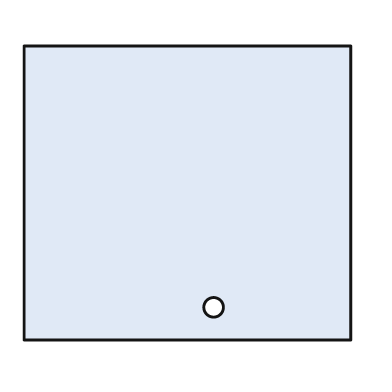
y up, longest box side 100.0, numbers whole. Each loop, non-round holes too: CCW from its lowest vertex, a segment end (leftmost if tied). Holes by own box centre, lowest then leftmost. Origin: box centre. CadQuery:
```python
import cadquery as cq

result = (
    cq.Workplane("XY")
    .moveTo(-50.0, -45.0)
    .lineTo(50.0, -45.0)
    .lineTo(50.0, 45.0)
    .lineTo(-50.0, 45.0)
    .close()
    .moveTo(8.0, -35.0)
    .circle(3.0)
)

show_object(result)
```